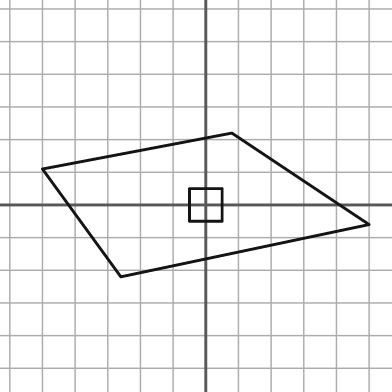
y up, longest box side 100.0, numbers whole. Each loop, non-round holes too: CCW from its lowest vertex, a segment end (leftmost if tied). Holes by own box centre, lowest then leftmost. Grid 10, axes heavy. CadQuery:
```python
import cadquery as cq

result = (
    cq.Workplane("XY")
    .moveTo(-26.0, -22.0)
    .lineTo(50.0, -6.0)
    .lineTo(8.0, 22.0)
    .lineTo(-50.0, 11.0)
    .close()
    .moveTo(-5.0, -5.0)
    .lineTo(5.0, -5.0)
    .lineTo(5.0, 5.0)
    .lineTo(-5.0, 5.0)
    .close()
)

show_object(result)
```